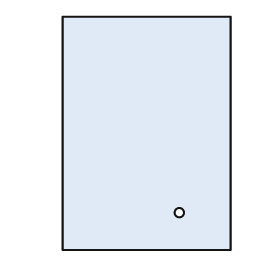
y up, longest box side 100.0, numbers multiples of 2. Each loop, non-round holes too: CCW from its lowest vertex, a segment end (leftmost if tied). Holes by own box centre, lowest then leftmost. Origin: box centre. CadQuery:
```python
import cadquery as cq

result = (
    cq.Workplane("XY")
    .moveTo(-36.0, -50.0)
    .lineTo(36.0, -50.0)
    .lineTo(36.0, 50.0)
    .lineTo(-36.0, 50.0)
    .close()
    .moveTo(14.0, -34.0)
    .circle(2.0)
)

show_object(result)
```